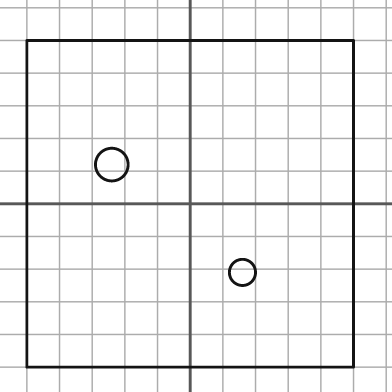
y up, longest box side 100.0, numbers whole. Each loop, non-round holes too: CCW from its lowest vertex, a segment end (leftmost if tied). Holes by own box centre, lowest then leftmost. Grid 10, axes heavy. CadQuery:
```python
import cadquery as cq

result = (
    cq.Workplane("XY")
    .moveTo(-50.0, -50.0)
    .lineTo(50.0, -50.0)
    .lineTo(50.0, 50.0)
    .lineTo(-50.0, 50.0)
    .close()
    .moveTo(16.0, -21.0)
    .circle(4.0)
    .moveTo(-24.0, 12.0)
    .circle(5.0)
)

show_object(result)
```